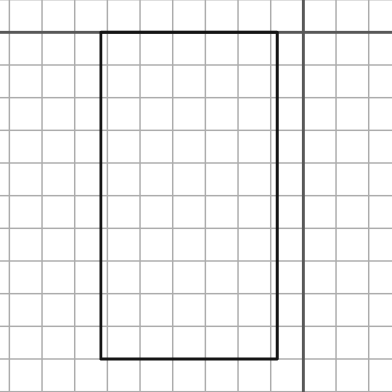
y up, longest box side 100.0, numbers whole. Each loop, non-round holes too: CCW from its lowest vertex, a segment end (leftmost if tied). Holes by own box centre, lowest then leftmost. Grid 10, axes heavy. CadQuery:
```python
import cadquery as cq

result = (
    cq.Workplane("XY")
    .moveTo(-62.0, -100.0)
    .lineTo(-8.0, -100.0)
    .lineTo(-8.0, 0.0)
    .lineTo(-62.0, 0.0)
    .close()
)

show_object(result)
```